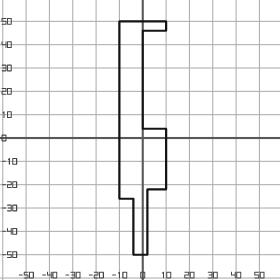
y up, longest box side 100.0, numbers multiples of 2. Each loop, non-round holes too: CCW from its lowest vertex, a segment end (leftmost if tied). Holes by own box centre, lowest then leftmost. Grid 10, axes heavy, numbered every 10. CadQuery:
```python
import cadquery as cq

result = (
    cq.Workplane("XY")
    .moveTo(-4.0, -50.0)
    .lineTo(2.0, -50.0)
    .lineTo(2.0, -22.0)
    .lineTo(10.0, -22.0)
    .lineTo(10.0, 4.0)
    .lineTo(0.0, 4.0)
    .lineTo(0.0, 46.0)
    .lineTo(10.0, 46.0)
    .lineTo(10.0, 50.0)
    .lineTo(-10.0, 50.0)
    .lineTo(-10.0, -26.0)
    .lineTo(-4.0, -26.0)
    .close()
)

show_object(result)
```